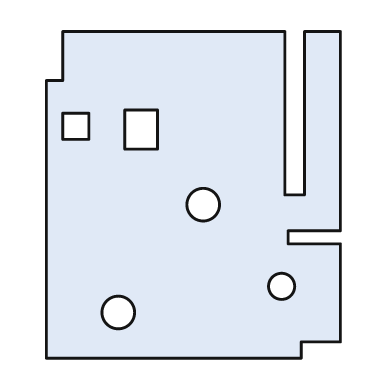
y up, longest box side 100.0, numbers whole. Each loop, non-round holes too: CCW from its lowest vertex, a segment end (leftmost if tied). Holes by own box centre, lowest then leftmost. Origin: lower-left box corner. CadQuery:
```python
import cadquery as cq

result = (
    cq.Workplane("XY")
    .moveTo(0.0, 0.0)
    .lineTo(78.0, 0.0)
    .lineTo(78.0, 5.0)
    .lineTo(90.0, 5.0)
    .lineTo(90.0, 35.0)
    .lineTo(74.0, 35.0)
    .lineTo(74.0, 39.0)
    .lineTo(90.0, 39.0)
    .lineTo(90.0, 100.0)
    .lineTo(79.0, 100.0)
    .lineTo(79.0, 50.0)
    .lineTo(73.0, 50.0)
    .lineTo(73.0, 100.0)
    .lineTo(5.0, 100.0)
    .lineTo(5.0, 85.0)
    .lineTo(0.0, 85.0)
    .close()
    .moveTo(22.0, 14.0)
    .circle(5.0)
    .moveTo(72.0, 22.0)
    .circle(4.0)
    .moveTo(48.0, 47.0)
    .circle(5.0)
    .moveTo(24.0, 64.0)
    .lineTo(34.0, 64.0)
    .lineTo(34.0, 76.0)
    .lineTo(24.0, 76.0)
    .close()
    .moveTo(5.0, 67.0)
    .lineTo(13.0, 67.0)
    .lineTo(13.0, 75.0)
    .lineTo(5.0, 75.0)
    .close()
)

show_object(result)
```